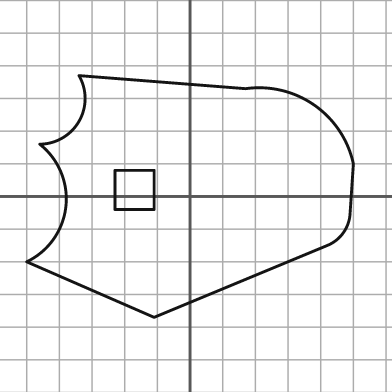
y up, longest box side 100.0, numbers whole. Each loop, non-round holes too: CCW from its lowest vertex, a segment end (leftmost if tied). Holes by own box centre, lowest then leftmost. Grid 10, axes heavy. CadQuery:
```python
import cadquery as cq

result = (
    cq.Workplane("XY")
    .moveTo(-11.0, -37.0)
    .lineTo(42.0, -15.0)
    .threePointArc((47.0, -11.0), (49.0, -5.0))
    .lineTo(50.0, 10.0)
    .threePointArc((38.0, 28.0), (17.0, 33.0))
    .lineTo(-34.0, 37.0)
    .threePointArc((-34.0, 23.0), (-46.0, 16.0))
    .threePointArc((-38.0, -3.0), (-50.0, -20.0))
    .close()
    .moveTo(-23.0, -4.0)
    .lineTo(-11.0, -4.0)
    .lineTo(-11.0, 8.0)
    .lineTo(-23.0, 8.0)
    .close()
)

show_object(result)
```